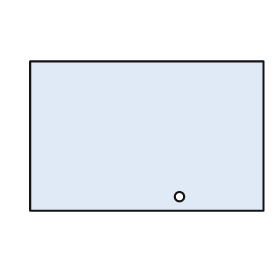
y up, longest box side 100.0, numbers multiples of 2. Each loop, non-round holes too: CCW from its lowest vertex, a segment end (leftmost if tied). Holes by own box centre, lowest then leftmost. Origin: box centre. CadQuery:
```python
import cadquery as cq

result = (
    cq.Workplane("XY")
    .moveTo(-50.0, -32.0)
    .lineTo(50.0, -32.0)
    .lineTo(50.0, 32.0)
    .lineTo(-50.0, 32.0)
    .close()
    .moveTo(14.0, -26.0)
    .circle(2.0)
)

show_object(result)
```